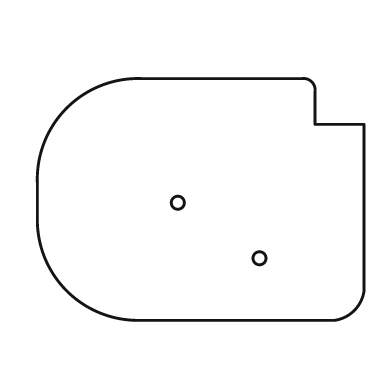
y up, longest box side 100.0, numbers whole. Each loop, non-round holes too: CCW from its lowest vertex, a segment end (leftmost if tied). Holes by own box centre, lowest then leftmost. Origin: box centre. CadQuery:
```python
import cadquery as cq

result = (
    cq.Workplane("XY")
    .moveTo(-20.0, -37.0)
    .lineTo(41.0, -37.0)
    .threePointArc((47.0, -34.0), (50.0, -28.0))
    .lineTo(50.0, 23.0)
    .lineTo(35.0, 23.0)
    .lineTo(35.0, 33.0)
    .threePointArc((34.0, 36.0), (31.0, 37.0))
    .lineTo(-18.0, 37.0)
    .threePointArc((-41.0, 28.0), (-50.0, 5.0))
    .lineTo(-50.0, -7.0)
    .threePointArc((-41.0, -28.0), (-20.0, -37.0))
    .close()
    .moveTo(18.0, -18.0)
    .circle(2.0)
    .moveTo(-7.0, -1.0)
    .circle(2.0)
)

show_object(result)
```